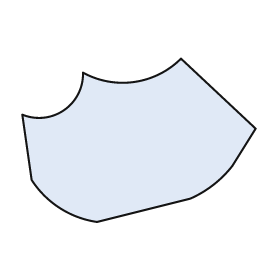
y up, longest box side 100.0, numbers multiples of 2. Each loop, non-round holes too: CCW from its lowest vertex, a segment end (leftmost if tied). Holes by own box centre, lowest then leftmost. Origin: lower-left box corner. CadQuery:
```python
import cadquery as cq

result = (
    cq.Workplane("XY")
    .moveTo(32.0, 0.0)
    .lineTo(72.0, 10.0)
    .threePointArc((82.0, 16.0), (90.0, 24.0))
    .lineTo(100.0, 40.0)
    .lineTo(68.0, 70.0)
    .threePointArc((48.0, 60.0), (26.0, 64.0))
    .threePointArc((18.0, 48.0), (0.0, 46.0))
    .lineTo(4.0, 18.0)
    .threePointArc((16.0, 6.0), (32.0, 0.0))
    .close()
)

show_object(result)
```